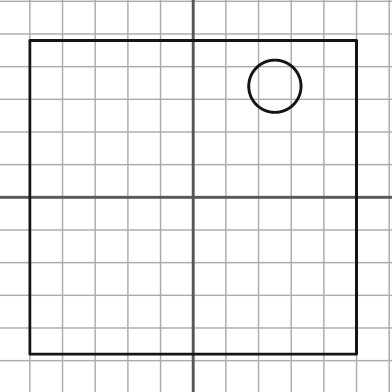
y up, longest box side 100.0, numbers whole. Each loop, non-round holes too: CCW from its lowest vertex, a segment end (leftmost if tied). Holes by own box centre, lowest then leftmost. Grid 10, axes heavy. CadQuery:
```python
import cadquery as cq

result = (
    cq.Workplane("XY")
    .moveTo(-50.0, -48.0)
    .lineTo(50.0, -48.0)
    .lineTo(50.0, 48.0)
    .lineTo(-50.0, 48.0)
    .close()
    .moveTo(25.0, 34.0)
    .circle(8.0)
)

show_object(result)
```